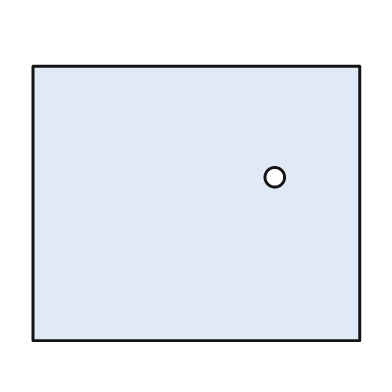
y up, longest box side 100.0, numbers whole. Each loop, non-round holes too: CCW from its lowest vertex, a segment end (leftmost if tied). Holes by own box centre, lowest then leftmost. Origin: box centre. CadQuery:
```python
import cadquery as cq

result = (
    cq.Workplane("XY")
    .moveTo(-50.0, -42.0)
    .lineTo(50.0, -42.0)
    .lineTo(50.0, 42.0)
    .lineTo(-50.0, 42.0)
    .close()
    .moveTo(24.0, 8.0)
    .circle(3.0)
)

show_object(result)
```